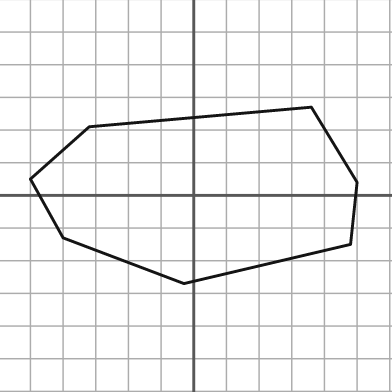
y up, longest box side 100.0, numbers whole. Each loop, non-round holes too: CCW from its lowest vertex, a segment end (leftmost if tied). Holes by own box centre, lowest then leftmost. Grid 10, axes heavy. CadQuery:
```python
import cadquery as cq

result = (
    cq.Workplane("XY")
    .moveTo(-3.0, -27.0)
    .lineTo(48.0, -15.0)
    .lineTo(50.0, 4.0)
    .lineTo(36.0, 27.0)
    .lineTo(-32.0, 21.0)
    .lineTo(-50.0, 5.0)
    .lineTo(-40.0, -13.0)
    .close()
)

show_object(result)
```